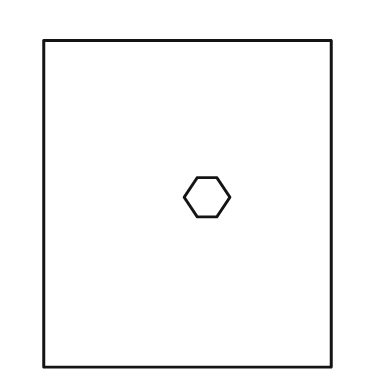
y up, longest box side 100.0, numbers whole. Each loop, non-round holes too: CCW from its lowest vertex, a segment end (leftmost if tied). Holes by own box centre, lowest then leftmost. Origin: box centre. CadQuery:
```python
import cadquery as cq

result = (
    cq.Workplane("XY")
    .moveTo(-44.0, -50.0)
    .lineTo(44.0, -50.0)
    .lineTo(44.0, 50.0)
    .lineTo(-44.0, 50.0)
    .close()
    .moveTo(3.0, -4.0)
    .lineTo(9.0, -4.0)
    .lineTo(13.0, 2.0)
    .lineTo(9.0, 8.0)
    .lineTo(3.0, 8.0)
    .lineTo(-1.0, 2.0)
    .close()
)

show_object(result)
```